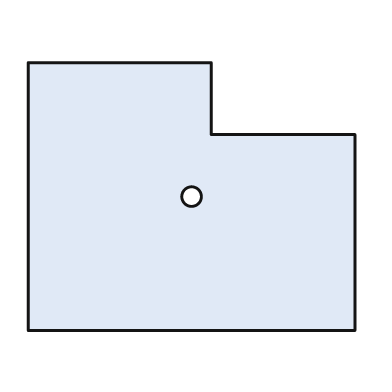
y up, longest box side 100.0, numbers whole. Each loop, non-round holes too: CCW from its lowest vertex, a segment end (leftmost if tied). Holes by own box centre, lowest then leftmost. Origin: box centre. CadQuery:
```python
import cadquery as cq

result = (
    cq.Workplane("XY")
    .moveTo(-50.0, -41.0)
    .lineTo(50.0, -41.0)
    .lineTo(50.0, 19.0)
    .lineTo(6.0, 19.0)
    .lineTo(6.0, 41.0)
    .lineTo(-50.0, 41.0)
    .close()
    .moveTo(0.0, 0.0)
    .circle(3.0)
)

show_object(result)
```